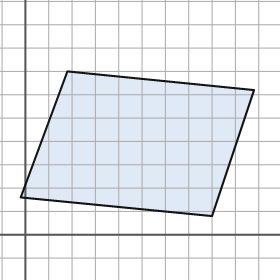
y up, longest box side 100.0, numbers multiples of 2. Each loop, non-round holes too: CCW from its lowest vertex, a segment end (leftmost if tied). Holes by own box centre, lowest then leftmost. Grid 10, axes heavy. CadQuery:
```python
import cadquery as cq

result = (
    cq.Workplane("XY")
    .moveTo(80.0, 8.0)
    .lineTo(98.0, 62.0)
    .lineTo(18.0, 70.0)
    .lineTo(-2.0, 16.0)
    .close()
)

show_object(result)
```